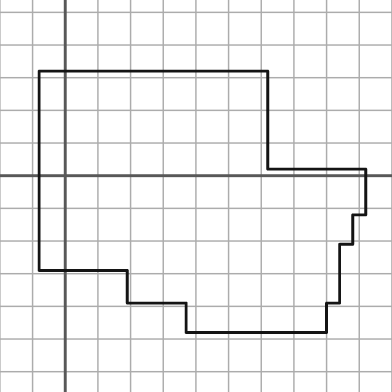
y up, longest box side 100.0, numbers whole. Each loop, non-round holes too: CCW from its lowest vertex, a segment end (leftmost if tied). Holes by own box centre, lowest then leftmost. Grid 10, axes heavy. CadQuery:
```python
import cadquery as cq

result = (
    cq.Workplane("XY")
    .moveTo(37.0, -48.0)
    .lineTo(80.0, -48.0)
    .lineTo(80.0, -39.0)
    .lineTo(84.0, -39.0)
    .lineTo(84.0, -21.0)
    .lineTo(88.0, -21.0)
    .lineTo(88.0, -12.0)
    .lineTo(92.0, -12.0)
    .lineTo(92.0, 2.0)
    .lineTo(62.0, 2.0)
    .lineTo(62.0, 32.0)
    .lineTo(-8.0, 32.0)
    .lineTo(-8.0, -29.0)
    .lineTo(19.0, -29.0)
    .lineTo(19.0, -39.0)
    .lineTo(37.0, -39.0)
    .close()
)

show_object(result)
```